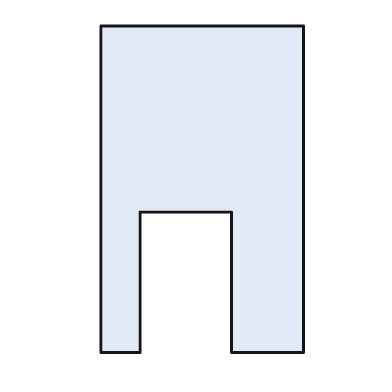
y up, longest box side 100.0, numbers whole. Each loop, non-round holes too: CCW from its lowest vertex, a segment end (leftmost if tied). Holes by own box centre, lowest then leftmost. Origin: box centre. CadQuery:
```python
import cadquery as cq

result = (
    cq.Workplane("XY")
    .moveTo(-31.0, -50.0)
    .lineTo(-19.0, -50.0)
    .lineTo(-19.0, -7.0)
    .lineTo(9.0, -7.0)
    .lineTo(9.0, -50.0)
    .lineTo(31.0, -50.0)
    .lineTo(31.0, 50.0)
    .lineTo(-31.0, 50.0)
    .close()
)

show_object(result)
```